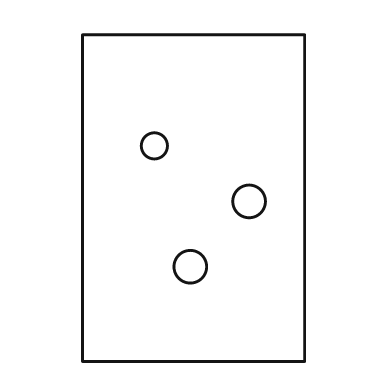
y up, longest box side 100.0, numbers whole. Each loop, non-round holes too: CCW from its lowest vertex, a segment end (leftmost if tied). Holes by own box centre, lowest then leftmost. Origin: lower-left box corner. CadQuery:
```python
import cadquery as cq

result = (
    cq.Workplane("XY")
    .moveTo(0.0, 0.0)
    .lineTo(68.0, 0.0)
    .lineTo(68.0, 100.0)
    .lineTo(0.0, 100.0)
    .close()
    .moveTo(33.0, 29.0)
    .circle(5.0)
    .moveTo(51.0, 49.0)
    .circle(5.0)
    .moveTo(22.0, 66.0)
    .circle(4.0)
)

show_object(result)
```